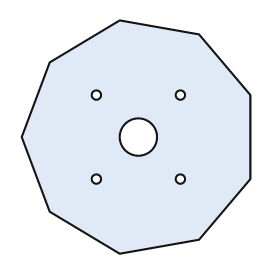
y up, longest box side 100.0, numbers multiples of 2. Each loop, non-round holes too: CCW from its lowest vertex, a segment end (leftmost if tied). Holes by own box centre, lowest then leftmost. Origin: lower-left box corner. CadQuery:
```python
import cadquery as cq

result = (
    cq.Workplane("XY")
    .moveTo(42.0, 0.0)
    .lineTo(76.0, 6.0)
    .lineTo(98.0, 32.0)
    .lineTo(98.0, 68.0)
    .lineTo(76.0, 94.0)
    .lineTo(42.0, 100.0)
    .lineTo(12.0, 82.0)
    .lineTo(0.0, 50.0)
    .lineTo(12.0, 18.0)
    .close()
    .moveTo(32.0, 32.0)
    .circle(2.0)
    .moveTo(68.0, 32.0)
    .circle(2.0)
    .moveTo(50.0, 50.0)
    .circle(8.0)
    .moveTo(32.0, 68.0)
    .circle(2.0)
    .moveTo(68.0, 68.0)
    .circle(2.0)
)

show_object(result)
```